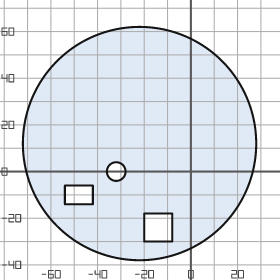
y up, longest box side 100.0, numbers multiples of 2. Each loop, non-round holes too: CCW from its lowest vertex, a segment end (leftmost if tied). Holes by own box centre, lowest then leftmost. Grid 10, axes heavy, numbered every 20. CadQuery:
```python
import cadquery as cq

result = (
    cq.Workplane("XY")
    .moveTo(-22.0, 12.0)
    .circle(50.0)
    .moveTo(-20.0, -30.0)
    .lineTo(-8.0, -30.0)
    .lineTo(-8.0, -18.0)
    .lineTo(-20.0, -18.0)
    .close()
    .moveTo(-54.0, -14.0)
    .lineTo(-42.0, -14.0)
    .lineTo(-42.0, -6.0)
    .lineTo(-54.0, -6.0)
    .close()
    .moveTo(-32.0, 0.0)
    .circle(4.0)
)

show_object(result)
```